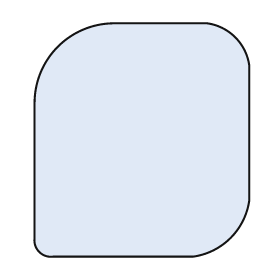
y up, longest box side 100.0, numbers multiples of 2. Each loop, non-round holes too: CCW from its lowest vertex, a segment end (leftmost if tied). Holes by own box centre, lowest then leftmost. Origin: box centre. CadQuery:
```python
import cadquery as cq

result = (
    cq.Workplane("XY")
    .moveTo(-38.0, -50.0)
    .lineTo(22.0, -50.0)
    .threePointArc((38.0, -42.0), (46.0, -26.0))
    .lineTo(46.0, 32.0)
    .threePointArc((40.0, 44.0), (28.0, 50.0))
    .lineTo(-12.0, 50.0)
    .threePointArc((-36.0, 40.0), (-46.0, 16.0))
    .lineTo(-46.0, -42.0)
    .threePointArc((-44.0, -48.0), (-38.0, -50.0))
    .close()
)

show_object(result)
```